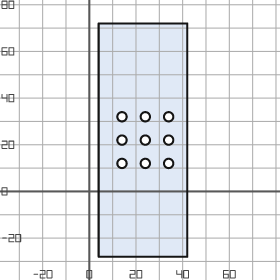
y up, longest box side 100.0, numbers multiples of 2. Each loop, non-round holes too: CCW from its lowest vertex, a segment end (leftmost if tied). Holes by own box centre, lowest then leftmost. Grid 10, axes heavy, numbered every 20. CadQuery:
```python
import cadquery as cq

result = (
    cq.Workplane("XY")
    .moveTo(4.0, -28.0)
    .lineTo(42.0, -28.0)
    .lineTo(42.0, 72.0)
    .lineTo(4.0, 72.0)
    .close()
    .moveTo(14.0, 12.0)
    .circle(2.0)
    .moveTo(24.0, 12.0)
    .circle(2.0)
    .moveTo(34.0, 12.0)
    .circle(2.0)
    .moveTo(14.0, 22.0)
    .circle(2.0)
    .moveTo(24.0, 22.0)
    .circle(2.0)
    .moveTo(34.0, 22.0)
    .circle(2.0)
    .moveTo(14.0, 32.0)
    .circle(2.0)
    .moveTo(24.0, 32.0)
    .circle(2.0)
    .moveTo(34.0, 32.0)
    .circle(2.0)
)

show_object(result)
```